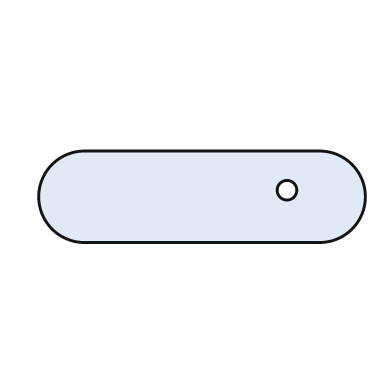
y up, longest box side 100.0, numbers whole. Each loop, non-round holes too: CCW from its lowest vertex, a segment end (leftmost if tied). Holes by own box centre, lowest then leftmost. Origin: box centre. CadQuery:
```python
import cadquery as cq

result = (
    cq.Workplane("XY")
    .moveTo(-36.0, -14.0)
    .lineTo(36.0, -14.0)
    .threePointArc((50.0, 0.0), (36.0, 14.0))
    .lineTo(-36.0, 14.0)
    .threePointArc((-50.0, 0.0), (-36.0, -14.0))
    .close()
    .moveTo(26.0, 2.0)
    .circle(3.0)
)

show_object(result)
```